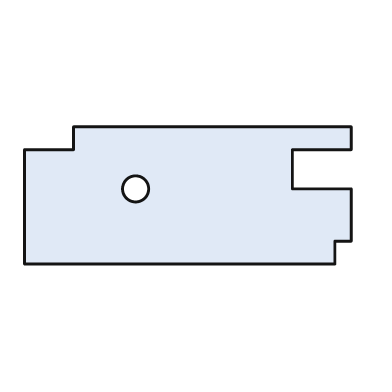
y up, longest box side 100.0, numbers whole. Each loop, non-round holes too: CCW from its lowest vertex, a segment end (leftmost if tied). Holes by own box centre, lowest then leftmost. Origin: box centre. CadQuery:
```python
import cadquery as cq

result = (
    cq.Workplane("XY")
    .moveTo(-50.0, -21.0)
    .lineTo(45.0, -21.0)
    .lineTo(45.0, -14.0)
    .lineTo(50.0, -14.0)
    .lineTo(50.0, 2.0)
    .lineTo(32.0, 2.0)
    .lineTo(32.0, 14.0)
    .lineTo(50.0, 14.0)
    .lineTo(50.0, 21.0)
    .lineTo(-35.0, 21.0)
    .lineTo(-35.0, 14.0)
    .lineTo(-50.0, 14.0)
    .close()
    .moveTo(-16.0, 2.0)
    .circle(4.0)
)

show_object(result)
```